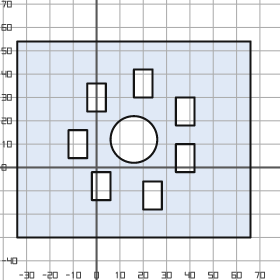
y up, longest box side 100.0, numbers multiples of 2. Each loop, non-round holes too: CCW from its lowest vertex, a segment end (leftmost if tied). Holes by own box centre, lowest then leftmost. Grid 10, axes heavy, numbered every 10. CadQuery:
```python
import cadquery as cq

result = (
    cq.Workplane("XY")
    .moveTo(-34.0, -30.0)
    .lineTo(66.0, -30.0)
    .lineTo(66.0, 54.0)
    .lineTo(-34.0, 54.0)
    .close()
    .moveTo(20.0, -18.0)
    .lineTo(28.0, -18.0)
    .lineTo(28.0, -6.0)
    .lineTo(20.0, -6.0)
    .close()
    .moveTo(-2.0, -14.0)
    .lineTo(6.0, -14.0)
    .lineTo(6.0, -2.0)
    .lineTo(-2.0, -2.0)
    .close()
    .moveTo(34.0, -2.0)
    .lineTo(42.0, -2.0)
    .lineTo(42.0, 10.0)
    .lineTo(34.0, 10.0)
    .close()
    .moveTo(-12.0, 4.0)
    .lineTo(-4.0, 4.0)
    .lineTo(-4.0, 16.0)
    .lineTo(-12.0, 16.0)
    .close()
    .moveTo(16.0, 12.0)
    .circle(10.0)
    .moveTo(34.0, 18.0)
    .lineTo(42.0, 18.0)
    .lineTo(42.0, 30.0)
    .lineTo(34.0, 30.0)
    .close()
    .moveTo(-4.0, 24.0)
    .lineTo(4.0, 24.0)
    .lineTo(4.0, 36.0)
    .lineTo(-4.0, 36.0)
    .close()
    .moveTo(16.0, 30.0)
    .lineTo(24.0, 30.0)
    .lineTo(24.0, 42.0)
    .lineTo(16.0, 42.0)
    .close()
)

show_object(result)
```